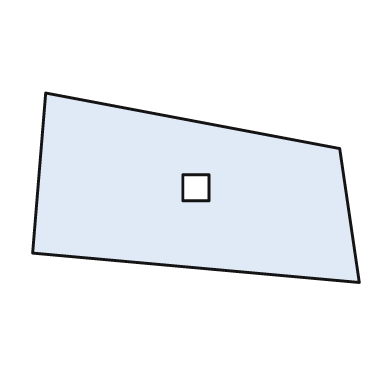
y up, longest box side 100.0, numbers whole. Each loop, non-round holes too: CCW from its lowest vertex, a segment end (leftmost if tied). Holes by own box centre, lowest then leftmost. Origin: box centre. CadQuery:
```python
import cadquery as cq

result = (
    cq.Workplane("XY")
    .moveTo(50.0, -29.0)
    .lineTo(44.0, 12.0)
    .lineTo(-46.0, 29.0)
    .lineTo(-50.0, -20.0)
    .close()
    .moveTo(-4.0, -4.0)
    .lineTo(4.0, -4.0)
    .lineTo(4.0, 4.0)
    .lineTo(-4.0, 4.0)
    .close()
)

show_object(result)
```